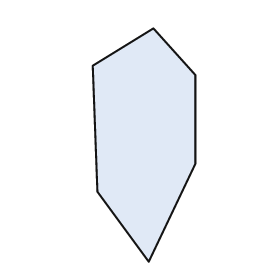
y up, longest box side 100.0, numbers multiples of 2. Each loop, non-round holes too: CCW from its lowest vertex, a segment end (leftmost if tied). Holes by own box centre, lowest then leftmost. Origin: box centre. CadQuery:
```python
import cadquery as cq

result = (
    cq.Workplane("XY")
    .moveTo(2.0, -50.0)
    .lineTo(22.0, -8.0)
    .lineTo(22.0, 30.0)
    .lineTo(4.0, 50.0)
    .lineTo(-22.0, 34.0)
    .lineTo(-20.0, -20.0)
    .close()
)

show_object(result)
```